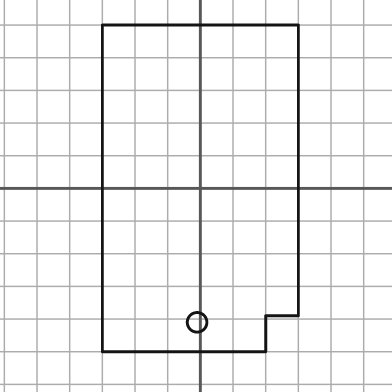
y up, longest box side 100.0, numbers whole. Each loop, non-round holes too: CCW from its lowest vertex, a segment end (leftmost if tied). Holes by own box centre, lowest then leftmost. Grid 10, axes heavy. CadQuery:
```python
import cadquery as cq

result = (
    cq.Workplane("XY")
    .moveTo(-30.0, -50.0)
    .lineTo(20.0, -50.0)
    .lineTo(20.0, -39.0)
    .lineTo(30.0, -39.0)
    .lineTo(30.0, 50.0)
    .lineTo(-30.0, 50.0)
    .close()
    .moveTo(-1.0, -41.0)
    .circle(3.0)
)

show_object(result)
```